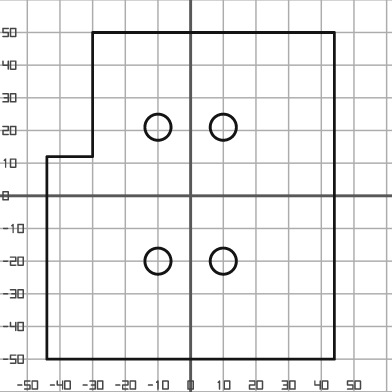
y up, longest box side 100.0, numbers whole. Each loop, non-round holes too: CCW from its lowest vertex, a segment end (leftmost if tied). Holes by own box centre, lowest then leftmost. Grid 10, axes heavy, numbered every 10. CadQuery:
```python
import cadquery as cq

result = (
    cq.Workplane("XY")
    .moveTo(-44.0, -50.0)
    .lineTo(44.0, -50.0)
    .lineTo(44.0, 50.0)
    .lineTo(-30.0, 50.0)
    .lineTo(-30.0, 12.0)
    .lineTo(-44.0, 12.0)
    .close()
    .moveTo(-10.0, -20.0)
    .circle(4.0)
    .moveTo(10.0, -20.0)
    .circle(4.0)
    .moveTo(-10.0, 21.0)
    .circle(4.0)
    .moveTo(10.0, 21.0)
    .circle(4.0)
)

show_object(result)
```